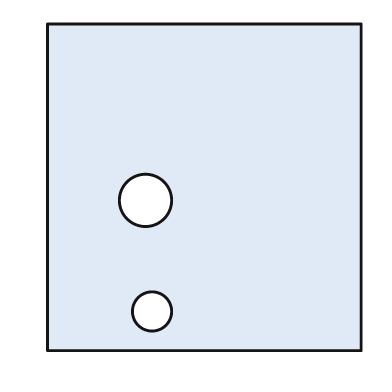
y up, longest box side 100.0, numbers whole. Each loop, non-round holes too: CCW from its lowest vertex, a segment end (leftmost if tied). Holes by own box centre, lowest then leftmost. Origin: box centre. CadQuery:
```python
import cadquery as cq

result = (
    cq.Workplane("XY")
    .moveTo(-48.0, -50.0)
    .lineTo(48.0, -50.0)
    .lineTo(48.0, 50.0)
    .lineTo(-48.0, 50.0)
    .close()
    .moveTo(-16.0, -38.0)
    .circle(6.0)
    .moveTo(-18.0, -4.0)
    .circle(8.0)
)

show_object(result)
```